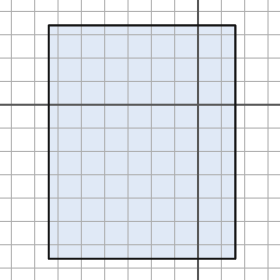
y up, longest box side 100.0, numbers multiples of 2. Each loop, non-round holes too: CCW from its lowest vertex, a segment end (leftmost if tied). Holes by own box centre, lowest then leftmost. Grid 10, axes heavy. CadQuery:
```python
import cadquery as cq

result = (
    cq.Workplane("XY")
    .moveTo(-64.0, -66.0)
    .lineTo(16.0, -66.0)
    .lineTo(16.0, 34.0)
    .lineTo(-64.0, 34.0)
    .close()
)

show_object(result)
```